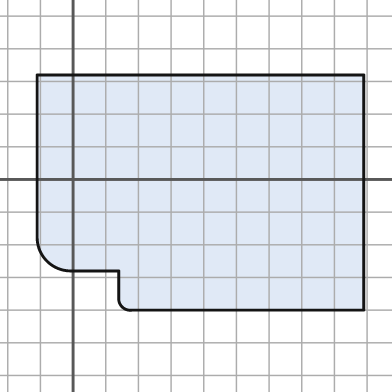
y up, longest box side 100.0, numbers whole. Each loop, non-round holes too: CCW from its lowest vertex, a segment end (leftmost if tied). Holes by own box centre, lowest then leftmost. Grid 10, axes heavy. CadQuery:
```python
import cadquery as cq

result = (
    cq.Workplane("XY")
    .moveTo(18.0, -40.0)
    .lineTo(89.0, -40.0)
    .lineTo(89.0, 32.0)
    .lineTo(-11.0, 32.0)
    .lineTo(-11.0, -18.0)
    .threePointArc((-8.0, -25.0), (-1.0, -28.0))
    .lineTo(14.0, -28.0)
    .lineTo(14.0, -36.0)
    .threePointArc((15.0, -39.0), (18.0, -40.0))
    .close()
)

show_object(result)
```